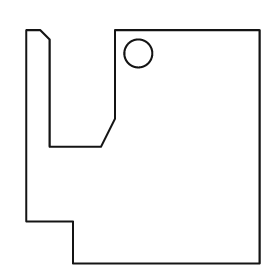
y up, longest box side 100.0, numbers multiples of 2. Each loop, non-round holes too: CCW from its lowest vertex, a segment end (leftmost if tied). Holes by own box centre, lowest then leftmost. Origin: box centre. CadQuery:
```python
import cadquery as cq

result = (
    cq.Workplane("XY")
    .moveTo(-30.0, -50.0)
    .lineTo(50.0, -50.0)
    .lineTo(50.0, 50.0)
    .lineTo(-12.0, 50.0)
    .lineTo(-12.0, 12.0)
    .lineTo(-18.0, 0.0)
    .lineTo(-40.0, 0.0)
    .lineTo(-40.0, 46.0)
    .lineTo(-44.0, 50.0)
    .lineTo(-50.0, 50.0)
    .lineTo(-50.0, -32.0)
    .lineTo(-30.0, -32.0)
    .close()
    .moveTo(-2.0, 40.0)
    .circle(6.0)
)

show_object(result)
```